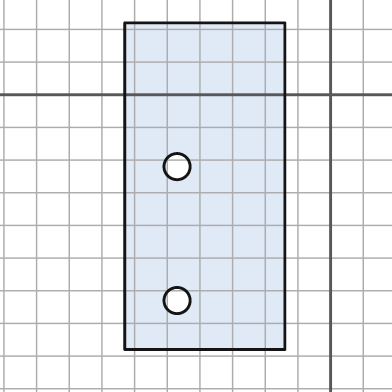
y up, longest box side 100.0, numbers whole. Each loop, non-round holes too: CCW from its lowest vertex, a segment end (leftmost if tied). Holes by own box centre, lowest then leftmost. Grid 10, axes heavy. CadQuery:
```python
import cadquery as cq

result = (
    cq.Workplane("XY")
    .moveTo(-63.0, -78.0)
    .lineTo(-14.0, -78.0)
    .lineTo(-14.0, 22.0)
    .lineTo(-63.0, 22.0)
    .close()
    .moveTo(-47.0, -63.0)
    .circle(4.0)
    .moveTo(-47.0, -22.0)
    .circle(4.0)
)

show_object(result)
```